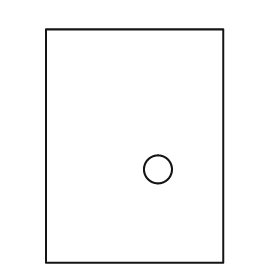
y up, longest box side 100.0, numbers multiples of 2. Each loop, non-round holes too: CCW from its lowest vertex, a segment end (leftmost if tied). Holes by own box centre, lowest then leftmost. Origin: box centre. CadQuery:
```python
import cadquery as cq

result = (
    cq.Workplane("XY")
    .moveTo(-38.0, -50.0)
    .lineTo(38.0, -50.0)
    .lineTo(38.0, 50.0)
    .lineTo(-38.0, 50.0)
    .close()
    .moveTo(10.0, -10.0)
    .circle(6.0)
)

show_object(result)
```